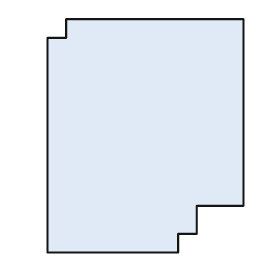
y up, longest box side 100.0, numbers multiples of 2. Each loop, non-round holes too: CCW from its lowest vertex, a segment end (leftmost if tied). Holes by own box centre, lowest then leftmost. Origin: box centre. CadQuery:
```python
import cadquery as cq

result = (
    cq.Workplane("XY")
    .moveTo(-42.0, -50.0)
    .lineTo(14.0, -50.0)
    .lineTo(14.0, -42.0)
    .lineTo(22.0, -42.0)
    .lineTo(22.0, -30.0)
    .lineTo(42.0, -30.0)
    .lineTo(42.0, 50.0)
    .lineTo(-34.0, 50.0)
    .lineTo(-34.0, 42.0)
    .lineTo(-42.0, 42.0)
    .close()
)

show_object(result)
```